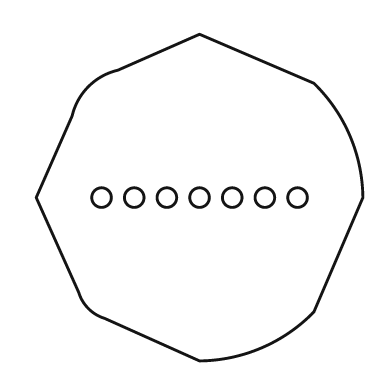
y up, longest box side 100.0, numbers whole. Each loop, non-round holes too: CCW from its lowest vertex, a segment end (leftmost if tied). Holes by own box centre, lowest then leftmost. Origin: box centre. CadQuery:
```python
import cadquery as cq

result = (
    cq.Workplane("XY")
    .moveTo(0.0, -50.0)
    .threePointArc((19.0, -46.0), (35.0, -35.0))
    .lineTo(50.0, 0.0)
    .threePointArc((46.0, 19.0), (35.0, 35.0))
    .lineTo(0.0, 50.0)
    .lineTo(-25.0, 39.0)
    .threePointArc((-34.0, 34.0), (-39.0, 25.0))
    .lineTo(-50.0, 0.0)
    .lineTo(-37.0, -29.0)
    .threePointArc((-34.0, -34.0), (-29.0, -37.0))
    .close()
    .moveTo(-30.0, 0.0)
    .circle(3.0)
    .moveTo(-20.0, 0.0)
    .circle(3.0)
    .moveTo(-10.0, 0.0)
    .circle(3.0)
    .moveTo(0.0, 0.0)
    .circle(3.0)
    .moveTo(10.0, 0.0)
    .circle(3.0)
    .moveTo(20.0, 0.0)
    .circle(3.0)
    .moveTo(30.0, 0.0)
    .circle(3.0)
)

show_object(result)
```